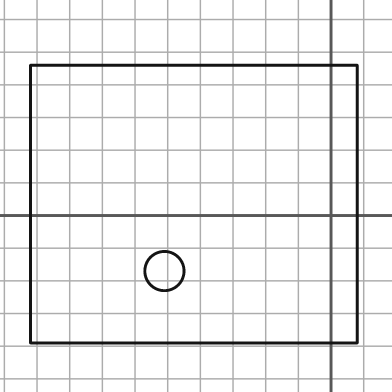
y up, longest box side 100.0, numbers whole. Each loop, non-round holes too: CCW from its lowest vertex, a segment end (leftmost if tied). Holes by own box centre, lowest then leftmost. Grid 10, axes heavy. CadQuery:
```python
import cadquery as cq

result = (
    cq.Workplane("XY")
    .moveTo(-92.0, -39.0)
    .lineTo(8.0, -39.0)
    .lineTo(8.0, 46.0)
    .lineTo(-92.0, 46.0)
    .close()
    .moveTo(-51.0, -17.0)
    .circle(6.0)
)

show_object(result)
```